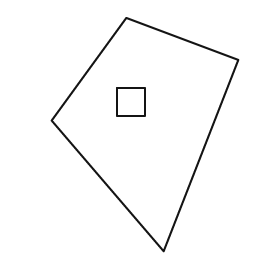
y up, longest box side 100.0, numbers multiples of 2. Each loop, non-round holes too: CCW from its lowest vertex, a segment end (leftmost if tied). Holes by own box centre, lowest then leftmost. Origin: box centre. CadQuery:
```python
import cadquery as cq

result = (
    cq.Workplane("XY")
    .moveTo(8.0, -50.0)
    .lineTo(40.0, 32.0)
    .lineTo(-8.0, 50.0)
    .lineTo(-40.0, 6.0)
    .close()
    .moveTo(-12.0, 8.0)
    .lineTo(0.0, 8.0)
    .lineTo(0.0, 20.0)
    .lineTo(-12.0, 20.0)
    .close()
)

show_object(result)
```